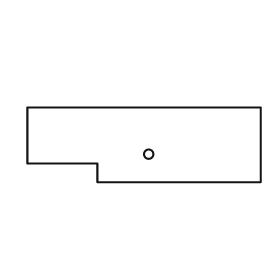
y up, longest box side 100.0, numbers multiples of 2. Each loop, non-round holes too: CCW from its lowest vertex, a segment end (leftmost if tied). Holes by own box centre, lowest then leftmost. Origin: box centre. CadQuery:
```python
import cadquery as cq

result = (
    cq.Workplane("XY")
    .moveTo(-20.0, -16.0)
    .lineTo(50.0, -16.0)
    .lineTo(50.0, 16.0)
    .lineTo(-50.0, 16.0)
    .lineTo(-50.0, -8.0)
    .lineTo(-20.0, -8.0)
    .close()
    .moveTo(2.0, -4.0)
    .circle(2.0)
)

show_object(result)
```